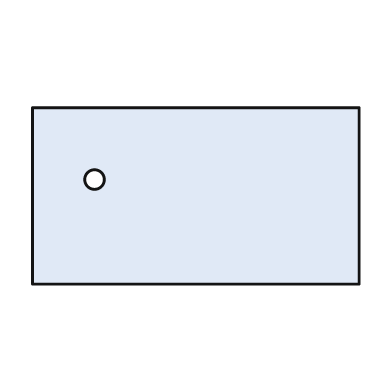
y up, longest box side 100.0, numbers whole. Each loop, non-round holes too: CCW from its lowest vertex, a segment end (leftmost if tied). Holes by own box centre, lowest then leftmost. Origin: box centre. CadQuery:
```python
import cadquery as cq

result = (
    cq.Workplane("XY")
    .moveTo(-50.0, -27.0)
    .lineTo(50.0, -27.0)
    .lineTo(50.0, 27.0)
    .lineTo(-50.0, 27.0)
    .close()
    .moveTo(-31.0, 5.0)
    .circle(3.0)
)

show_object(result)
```